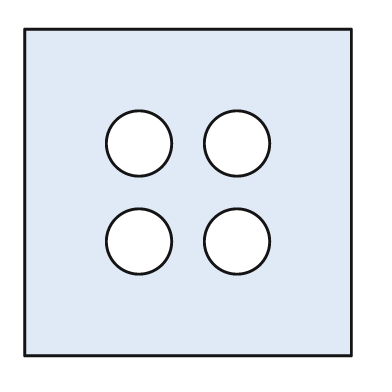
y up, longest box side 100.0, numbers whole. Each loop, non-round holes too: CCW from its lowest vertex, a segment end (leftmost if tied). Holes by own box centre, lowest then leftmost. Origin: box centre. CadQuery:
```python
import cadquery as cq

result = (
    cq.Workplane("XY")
    .moveTo(-50.0, -50.0)
    .lineTo(50.0, -50.0)
    .lineTo(50.0, 50.0)
    .lineTo(-50.0, 50.0)
    .close()
    .moveTo(-15.0, -15.0)
    .circle(10.0)
    .moveTo(15.0, -15.0)
    .circle(10.0)
    .moveTo(-15.0, 15.0)
    .circle(10.0)
    .moveTo(15.0, 15.0)
    .circle(10.0)
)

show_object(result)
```